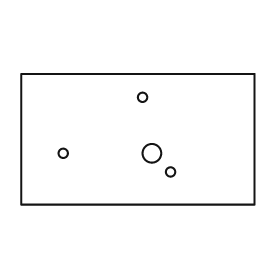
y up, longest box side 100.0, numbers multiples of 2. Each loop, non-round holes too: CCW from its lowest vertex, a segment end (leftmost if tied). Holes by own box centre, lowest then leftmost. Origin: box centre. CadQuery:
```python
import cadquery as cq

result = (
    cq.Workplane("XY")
    .moveTo(-50.0, -28.0)
    .lineTo(50.0, -28.0)
    .lineTo(50.0, 28.0)
    .lineTo(-50.0, 28.0)
    .close()
    .moveTo(14.0, -14.0)
    .circle(2.0)
    .moveTo(-32.0, -6.0)
    .circle(2.0)
    .moveTo(6.0, -6.0)
    .circle(4.0)
    .moveTo(2.0, 18.0)
    .circle(2.0)
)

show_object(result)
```